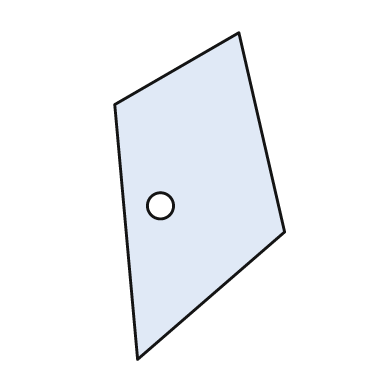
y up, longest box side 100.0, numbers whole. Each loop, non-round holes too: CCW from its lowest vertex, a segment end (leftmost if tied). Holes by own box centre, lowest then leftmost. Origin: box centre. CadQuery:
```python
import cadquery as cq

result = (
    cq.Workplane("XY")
    .moveTo(-19.0, -50.0)
    .lineTo(26.0, -11.0)
    .lineTo(12.0, 50.0)
    .lineTo(-26.0, 28.0)
    .close()
    .moveTo(-12.0, -3.0)
    .circle(4.0)
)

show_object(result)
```